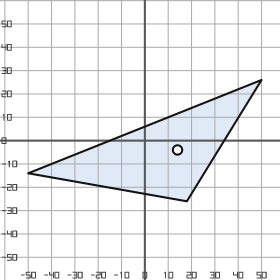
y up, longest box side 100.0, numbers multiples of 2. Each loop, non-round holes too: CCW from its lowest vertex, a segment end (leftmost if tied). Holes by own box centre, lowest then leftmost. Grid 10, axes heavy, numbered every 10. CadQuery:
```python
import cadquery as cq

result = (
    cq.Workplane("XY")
    .moveTo(18.0, -26.0)
    .lineTo(50.0, 26.0)
    .lineTo(-50.0, -14.0)
    .close()
    .moveTo(14.0, -4.0)
    .circle(2.0)
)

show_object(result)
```